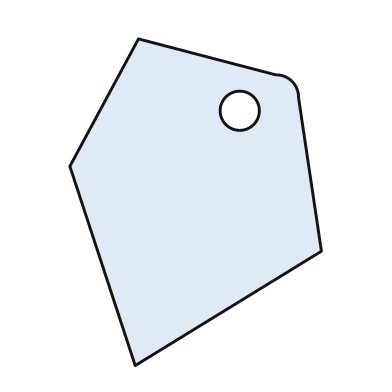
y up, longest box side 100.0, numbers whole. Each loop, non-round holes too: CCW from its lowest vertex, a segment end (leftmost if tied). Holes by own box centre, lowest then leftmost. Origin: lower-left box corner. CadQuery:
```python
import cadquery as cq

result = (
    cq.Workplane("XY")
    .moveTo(20.0, 0.0)
    .lineTo(77.0, 35.0)
    .lineTo(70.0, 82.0)
    .threePointArc((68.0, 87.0), (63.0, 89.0))
    .lineTo(21.0, 100.0)
    .lineTo(0.0, 61.0)
    .close()
    .moveTo(52.0, 78.0)
    .circle(6.0)
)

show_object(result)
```